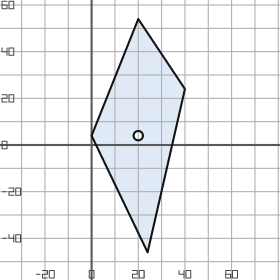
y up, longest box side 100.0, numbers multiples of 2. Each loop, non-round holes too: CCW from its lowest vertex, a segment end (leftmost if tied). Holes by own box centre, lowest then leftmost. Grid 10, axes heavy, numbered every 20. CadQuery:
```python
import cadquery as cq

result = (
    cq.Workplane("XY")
    .moveTo(24.0, -46.0)
    .lineTo(40.0, 24.0)
    .lineTo(20.0, 54.0)
    .lineTo(0.0, 4.0)
    .close()
    .moveTo(20.0, 4.0)
    .circle(2.0)
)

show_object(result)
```